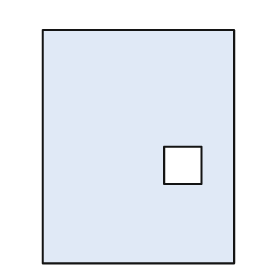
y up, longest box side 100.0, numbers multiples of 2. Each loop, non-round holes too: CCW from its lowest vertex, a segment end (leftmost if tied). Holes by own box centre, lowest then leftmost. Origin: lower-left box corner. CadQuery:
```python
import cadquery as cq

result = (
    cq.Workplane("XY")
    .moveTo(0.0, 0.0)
    .lineTo(82.0, 0.0)
    .lineTo(82.0, 100.0)
    .lineTo(0.0, 100.0)
    .close()
    .moveTo(52.0, 34.0)
    .lineTo(68.0, 34.0)
    .lineTo(68.0, 50.0)
    .lineTo(52.0, 50.0)
    .close()
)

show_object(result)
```